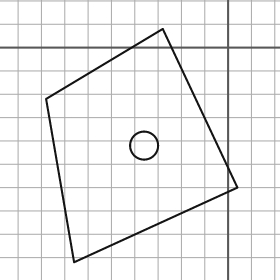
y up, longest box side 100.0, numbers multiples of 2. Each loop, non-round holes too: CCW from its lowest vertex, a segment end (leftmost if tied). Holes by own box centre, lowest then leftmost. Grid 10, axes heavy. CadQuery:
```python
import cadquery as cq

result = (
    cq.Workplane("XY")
    .moveTo(-66.0, -92.0)
    .lineTo(4.0, -60.0)
    .lineTo(-28.0, 8.0)
    .lineTo(-78.0, -22.0)
    .close()
    .moveTo(-36.0, -42.0)
    .circle(6.0)
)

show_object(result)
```